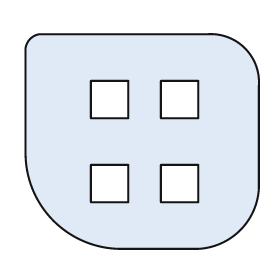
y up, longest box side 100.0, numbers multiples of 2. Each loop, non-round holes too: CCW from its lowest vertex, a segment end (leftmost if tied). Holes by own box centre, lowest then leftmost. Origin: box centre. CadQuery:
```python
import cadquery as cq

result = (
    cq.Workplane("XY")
    .moveTo(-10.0, -46.0)
    .lineTo(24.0, -46.0)
    .threePointArc((42.0, -38.0), (50.0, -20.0))
    .lineTo(50.0, 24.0)
    .threePointArc((44.0, 40.0), (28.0, 46.0))
    .lineTo(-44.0, 46.0)
    .threePointArc((-48.0, 44.0), (-50.0, 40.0))
    .lineTo(-50.0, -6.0)
    .threePointArc((-38.0, -34.0), (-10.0, -46.0))
    .close()
    .moveTo(-22.0, -26.0)
    .lineTo(-6.0, -26.0)
    .lineTo(-6.0, -10.0)
    .lineTo(-22.0, -10.0)
    .close()
    .moveTo(8.0, -26.0)
    .lineTo(24.0, -26.0)
    .lineTo(24.0, -10.0)
    .lineTo(8.0, -10.0)
    .close()
    .moveTo(-22.0, 10.0)
    .lineTo(-6.0, 10.0)
    .lineTo(-6.0, 26.0)
    .lineTo(-22.0, 26.0)
    .close()
    .moveTo(8.0, 10.0)
    .lineTo(24.0, 10.0)
    .lineTo(24.0, 26.0)
    .lineTo(8.0, 26.0)
    .close()
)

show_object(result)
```